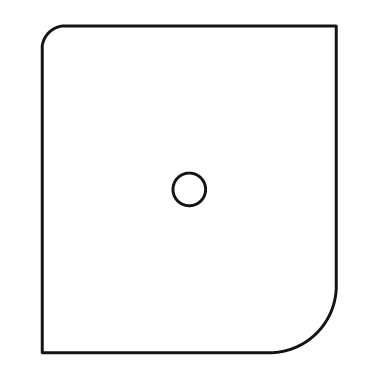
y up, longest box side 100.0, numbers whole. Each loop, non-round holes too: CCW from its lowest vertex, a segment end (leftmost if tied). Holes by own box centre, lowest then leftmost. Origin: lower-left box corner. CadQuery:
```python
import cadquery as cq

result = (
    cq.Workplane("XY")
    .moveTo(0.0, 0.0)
    .lineTo(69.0, 0.0)
    .threePointArc((84.0, 6.0), (90.0, 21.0))
    .lineTo(90.0, 100.0)
    .lineTo(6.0, 100.0)
    .threePointArc((2.0, 98.0), (0.0, 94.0))
    .close()
    .moveTo(45.0, 50.0)
    .circle(5.0)
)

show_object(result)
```